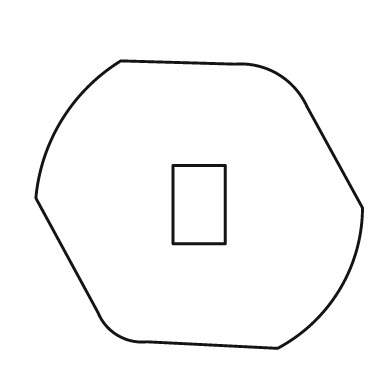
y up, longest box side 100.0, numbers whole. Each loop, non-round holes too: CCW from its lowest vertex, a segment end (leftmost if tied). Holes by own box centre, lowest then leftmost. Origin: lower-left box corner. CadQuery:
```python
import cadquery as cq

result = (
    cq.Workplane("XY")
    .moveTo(74.0, 0.0)
    .threePointArc((93.0, 18.0), (100.0, 43.0))
    .lineTo(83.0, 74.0)
    .threePointArc((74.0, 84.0), (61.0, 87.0))
    .lineTo(26.0, 88.0)
    .threePointArc((8.0, 70.0), (0.0, 46.0))
    .lineTo(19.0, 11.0)
    .threePointArc((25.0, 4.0), (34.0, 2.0))
    .close()
    .moveTo(42.0, 32.0)
    .lineTo(58.0, 32.0)
    .lineTo(58.0, 56.0)
    .lineTo(42.0, 56.0)
    .close()
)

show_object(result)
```